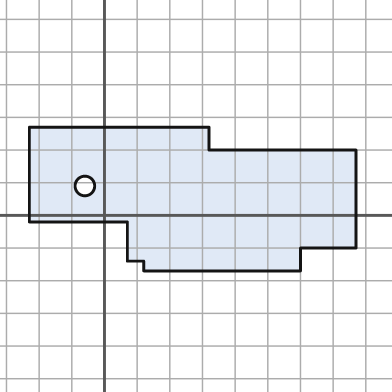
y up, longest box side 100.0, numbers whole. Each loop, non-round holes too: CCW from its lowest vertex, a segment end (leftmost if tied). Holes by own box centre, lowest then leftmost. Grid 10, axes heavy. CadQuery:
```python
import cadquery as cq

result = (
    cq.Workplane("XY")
    .moveTo(12.0, -17.0)
    .lineTo(60.0, -17.0)
    .lineTo(60.0, -10.0)
    .lineTo(77.0, -10.0)
    .lineTo(77.0, 20.0)
    .lineTo(32.0, 20.0)
    .lineTo(32.0, 27.0)
    .lineTo(-23.0, 27.0)
    .lineTo(-23.0, -2.0)
    .lineTo(7.0, -2.0)
    .lineTo(7.0, -14.0)
    .lineTo(12.0, -14.0)
    .close()
    .moveTo(-6.0, 9.0)
    .circle(3.0)
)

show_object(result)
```